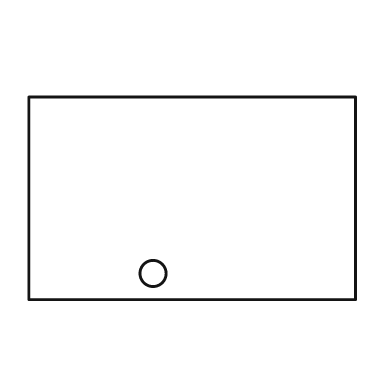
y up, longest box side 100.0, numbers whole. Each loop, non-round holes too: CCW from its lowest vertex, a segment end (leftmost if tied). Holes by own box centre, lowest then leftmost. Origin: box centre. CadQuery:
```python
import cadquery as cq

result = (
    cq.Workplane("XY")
    .moveTo(-50.0, -31.0)
    .lineTo(50.0, -31.0)
    .lineTo(50.0, 31.0)
    .lineTo(-50.0, 31.0)
    .close()
    .moveTo(-12.0, -23.0)
    .circle(4.0)
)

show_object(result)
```